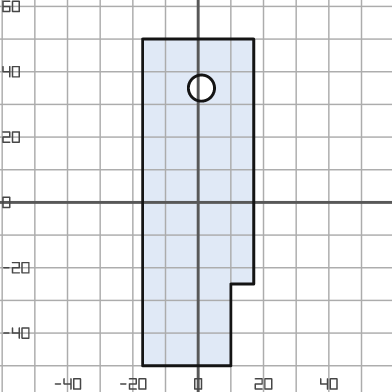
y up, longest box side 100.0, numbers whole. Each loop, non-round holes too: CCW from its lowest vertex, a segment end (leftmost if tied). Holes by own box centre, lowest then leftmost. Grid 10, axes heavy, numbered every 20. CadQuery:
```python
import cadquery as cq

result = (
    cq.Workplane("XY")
    .moveTo(-17.0, -50.0)
    .lineTo(10.0, -50.0)
    .lineTo(10.0, -25.0)
    .lineTo(17.0, -25.0)
    .lineTo(17.0, 50.0)
    .lineTo(-17.0, 50.0)
    .close()
    .moveTo(1.0, 35.0)
    .circle(4.0)
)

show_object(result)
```